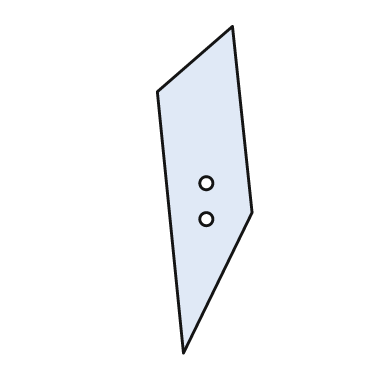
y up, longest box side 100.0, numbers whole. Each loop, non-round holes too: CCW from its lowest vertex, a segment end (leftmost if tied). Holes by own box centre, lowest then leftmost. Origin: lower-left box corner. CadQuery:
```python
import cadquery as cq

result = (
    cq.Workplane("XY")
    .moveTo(8.0, 0.0)
    .lineTo(29.0, 43.0)
    .lineTo(23.0, 100.0)
    .lineTo(0.0, 80.0)
    .close()
    .moveTo(15.0, 41.0)
    .circle(2.0)
    .moveTo(15.0, 52.0)
    .circle(2.0)
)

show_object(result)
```